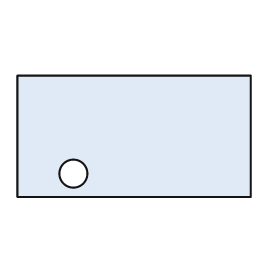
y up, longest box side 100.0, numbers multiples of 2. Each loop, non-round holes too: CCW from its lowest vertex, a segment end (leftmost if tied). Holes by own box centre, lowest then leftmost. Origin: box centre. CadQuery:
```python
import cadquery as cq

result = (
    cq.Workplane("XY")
    .moveTo(-50.0, -26.0)
    .lineTo(50.0, -26.0)
    .lineTo(50.0, 26.0)
    .lineTo(-50.0, 26.0)
    .close()
    .moveTo(-26.0, -16.0)
    .circle(6.0)
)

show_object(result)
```